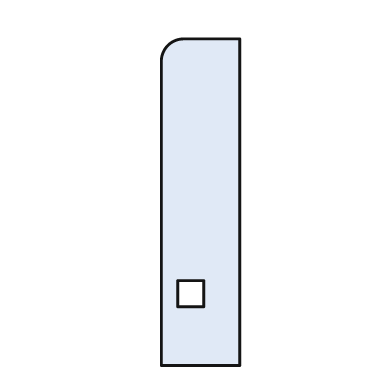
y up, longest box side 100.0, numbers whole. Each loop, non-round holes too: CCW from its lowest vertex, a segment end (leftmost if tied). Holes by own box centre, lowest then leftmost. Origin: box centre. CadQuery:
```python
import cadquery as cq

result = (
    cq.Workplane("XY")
    .moveTo(-12.0, -50.0)
    .lineTo(12.0, -50.0)
    .lineTo(12.0, 50.0)
    .lineTo(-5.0, 50.0)
    .threePointArc((-10.0, 48.0), (-12.0, 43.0))
    .close()
    .moveTo(-7.0, -32.0)
    .lineTo(1.0, -32.0)
    .lineTo(1.0, -24.0)
    .lineTo(-7.0, -24.0)
    .close()
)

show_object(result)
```